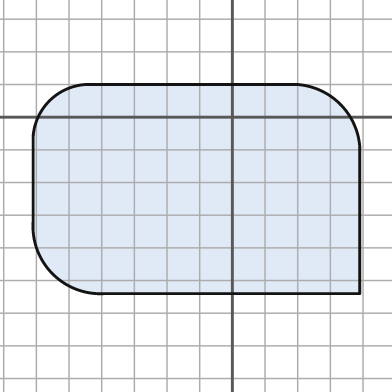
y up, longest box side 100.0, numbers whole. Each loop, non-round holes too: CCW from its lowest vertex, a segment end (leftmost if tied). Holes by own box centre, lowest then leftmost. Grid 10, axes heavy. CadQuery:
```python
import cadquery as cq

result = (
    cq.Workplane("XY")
    .moveTo(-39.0, -54.0)
    .lineTo(39.0, -54.0)
    .lineTo(39.0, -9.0)
    .threePointArc((33.0, 4.0), (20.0, 10.0))
    .lineTo(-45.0, 10.0)
    .threePointArc((-56.0, 5.0), (-61.0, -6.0))
    .lineTo(-61.0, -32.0)
    .threePointArc((-55.0, -48.0), (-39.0, -54.0))
    .close()
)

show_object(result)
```